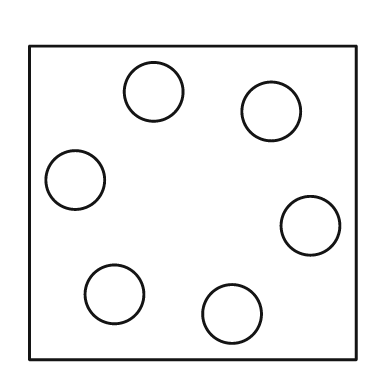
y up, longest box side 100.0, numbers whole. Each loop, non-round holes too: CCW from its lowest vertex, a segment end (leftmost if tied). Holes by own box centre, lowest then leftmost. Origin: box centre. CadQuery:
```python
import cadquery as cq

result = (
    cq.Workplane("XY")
    .moveTo(-50.0, -48.0)
    .lineTo(50.0, -48.0)
    .lineTo(50.0, 48.0)
    .lineTo(-50.0, 48.0)
    .close()
    .moveTo(12.0, -34.0)
    .circle(9.0)
    .moveTo(-24.0, -28.0)
    .circle(9.0)
    .moveTo(36.0, -7.0)
    .circle(9.0)
    .moveTo(-36.0, 7.0)
    .circle(9.0)
    .moveTo(24.0, 28.0)
    .circle(9.0)
    .moveTo(-12.0, 34.0)
    .circle(9.0)
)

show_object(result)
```